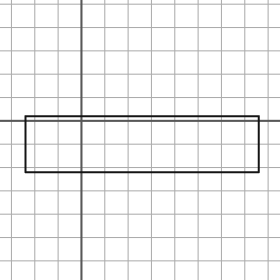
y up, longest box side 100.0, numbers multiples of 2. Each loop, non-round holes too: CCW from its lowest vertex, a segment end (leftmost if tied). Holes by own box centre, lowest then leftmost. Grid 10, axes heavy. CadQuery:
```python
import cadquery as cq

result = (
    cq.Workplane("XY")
    .moveTo(-24.0, -22.0)
    .lineTo(76.0, -22.0)
    .lineTo(76.0, 2.0)
    .lineTo(-24.0, 2.0)
    .close()
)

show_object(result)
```